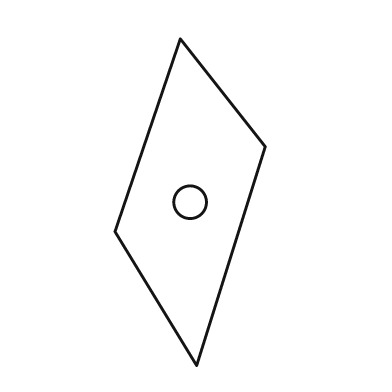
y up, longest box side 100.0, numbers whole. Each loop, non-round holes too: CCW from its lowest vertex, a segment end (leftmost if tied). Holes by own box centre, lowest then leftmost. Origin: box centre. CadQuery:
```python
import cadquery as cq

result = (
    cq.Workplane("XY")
    .moveTo(2.0, -50.0)
    .lineTo(23.0, 17.0)
    .lineTo(-3.0, 50.0)
    .lineTo(-23.0, -9.0)
    .close()
    .moveTo(0.0, 0.0)
    .circle(5.0)
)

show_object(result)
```